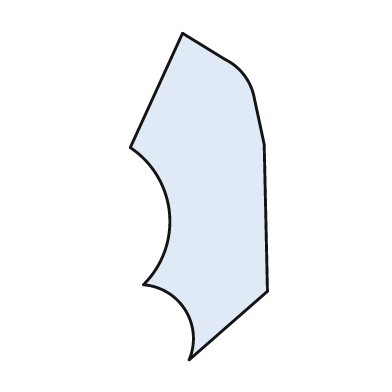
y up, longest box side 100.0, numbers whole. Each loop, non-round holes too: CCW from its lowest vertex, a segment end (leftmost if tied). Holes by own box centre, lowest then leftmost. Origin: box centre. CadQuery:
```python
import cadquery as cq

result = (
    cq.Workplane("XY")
    .moveTo(-3.0, -50.0)
    .lineTo(21.0, -29.0)
    .lineTo(20.0, 16.0)
    .lineTo(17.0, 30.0)
    .threePointArc((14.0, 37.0), (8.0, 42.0))
    .lineTo(-5.0, 50.0)
    .lineTo(-21.0, 15.0)
    .threePointArc((-9.0, -5.0), (-17.0, -27.0))
    .threePointArc((-4.0, -35.0), (-3.0, -50.0))
    .close()
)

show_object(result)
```